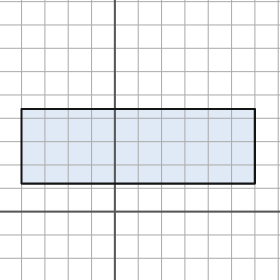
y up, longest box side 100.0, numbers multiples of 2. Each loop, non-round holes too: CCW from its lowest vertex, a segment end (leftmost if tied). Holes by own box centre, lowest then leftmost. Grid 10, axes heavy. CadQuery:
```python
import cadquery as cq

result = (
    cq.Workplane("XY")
    .moveTo(-40.0, 12.0)
    .lineTo(60.0, 12.0)
    .lineTo(60.0, 44.0)
    .lineTo(-40.0, 44.0)
    .close()
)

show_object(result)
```